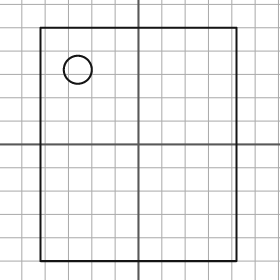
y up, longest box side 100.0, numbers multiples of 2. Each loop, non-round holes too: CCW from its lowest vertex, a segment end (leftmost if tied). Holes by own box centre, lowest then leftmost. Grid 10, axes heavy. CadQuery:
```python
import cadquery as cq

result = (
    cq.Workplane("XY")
    .moveTo(-42.0, -50.0)
    .lineTo(42.0, -50.0)
    .lineTo(42.0, 50.0)
    .lineTo(-42.0, 50.0)
    .close()
    .moveTo(-26.0, 32.0)
    .circle(6.0)
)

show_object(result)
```